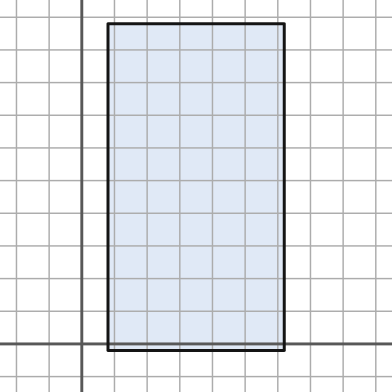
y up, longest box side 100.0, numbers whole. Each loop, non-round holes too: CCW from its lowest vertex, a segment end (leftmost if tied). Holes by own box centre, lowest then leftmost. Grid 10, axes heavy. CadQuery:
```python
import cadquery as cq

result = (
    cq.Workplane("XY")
    .moveTo(8.0, -2.0)
    .lineTo(62.0, -2.0)
    .lineTo(62.0, 98.0)
    .lineTo(8.0, 98.0)
    .close()
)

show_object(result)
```